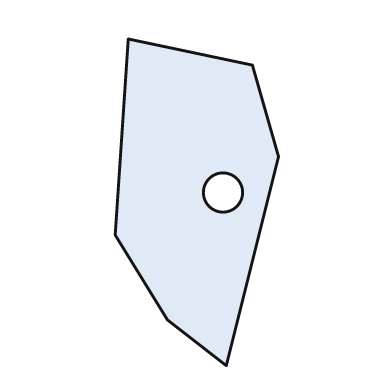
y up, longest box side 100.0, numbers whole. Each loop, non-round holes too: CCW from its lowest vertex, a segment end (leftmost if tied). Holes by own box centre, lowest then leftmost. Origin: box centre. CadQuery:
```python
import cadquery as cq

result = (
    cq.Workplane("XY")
    .moveTo(9.0, -50.0)
    .lineTo(25.0, 14.0)
    .lineTo(17.0, 42.0)
    .lineTo(-21.0, 50.0)
    .lineTo(-25.0, -10.0)
    .lineTo(-9.0, -36.0)
    .close()
    .moveTo(8.0, 3.0)
    .circle(6.0)
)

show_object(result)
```